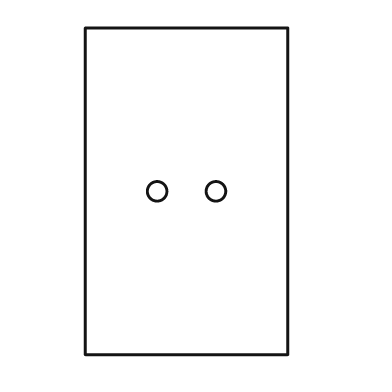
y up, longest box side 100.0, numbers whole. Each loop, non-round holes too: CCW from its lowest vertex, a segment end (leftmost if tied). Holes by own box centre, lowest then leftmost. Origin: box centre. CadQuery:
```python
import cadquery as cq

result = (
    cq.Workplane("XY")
    .moveTo(-31.0, -50.0)
    .lineTo(31.0, -50.0)
    .lineTo(31.0, 50.0)
    .lineTo(-31.0, 50.0)
    .close()
    .moveTo(-9.0, 0.0)
    .circle(3.0)
    .moveTo(9.0, 0.0)
    .circle(3.0)
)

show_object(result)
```